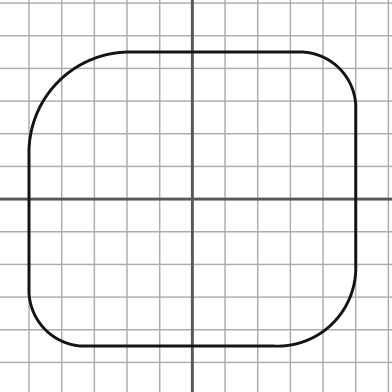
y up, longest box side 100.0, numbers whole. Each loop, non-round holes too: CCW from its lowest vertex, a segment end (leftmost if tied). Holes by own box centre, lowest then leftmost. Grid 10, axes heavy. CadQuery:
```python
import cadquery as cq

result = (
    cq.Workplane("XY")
    .moveTo(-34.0, -45.0)
    .lineTo(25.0, -45.0)
    .threePointArc((43.0, -38.0), (50.0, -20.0))
    .lineTo(50.0, 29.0)
    .threePointArc((45.0, 40.0), (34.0, 45.0))
    .lineTo(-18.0, 45.0)
    .threePointArc((-41.0, 36.0), (-50.0, 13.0))
    .lineTo(-50.0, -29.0)
    .threePointArc((-45.0, -40.0), (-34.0, -45.0))
    .close()
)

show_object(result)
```